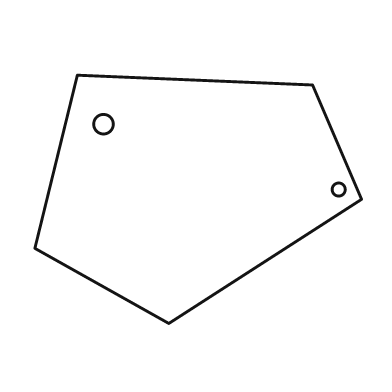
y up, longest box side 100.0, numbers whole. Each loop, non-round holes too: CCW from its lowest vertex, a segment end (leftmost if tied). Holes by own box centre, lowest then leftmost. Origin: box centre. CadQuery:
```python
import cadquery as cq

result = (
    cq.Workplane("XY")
    .moveTo(-9.0, -38.0)
    .lineTo(50.0, 0.0)
    .lineTo(35.0, 35.0)
    .lineTo(-37.0, 38.0)
    .lineTo(-50.0, -15.0)
    .close()
    .moveTo(43.0, 3.0)
    .circle(2.0)
    .moveTo(-29.0, 23.0)
    .circle(3.0)
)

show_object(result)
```